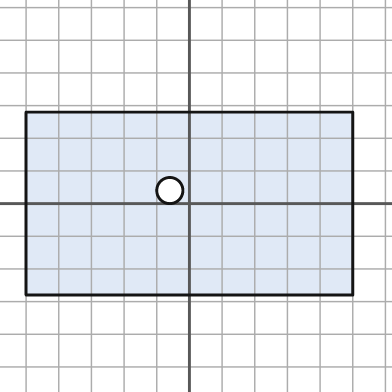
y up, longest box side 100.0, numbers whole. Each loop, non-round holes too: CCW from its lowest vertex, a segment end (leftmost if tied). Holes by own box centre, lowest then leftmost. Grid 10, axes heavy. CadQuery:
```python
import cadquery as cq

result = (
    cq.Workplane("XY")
    .moveTo(-50.0, -28.0)
    .lineTo(50.0, -28.0)
    .lineTo(50.0, 28.0)
    .lineTo(-50.0, 28.0)
    .close()
    .moveTo(-6.0, 4.0)
    .circle(4.0)
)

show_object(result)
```